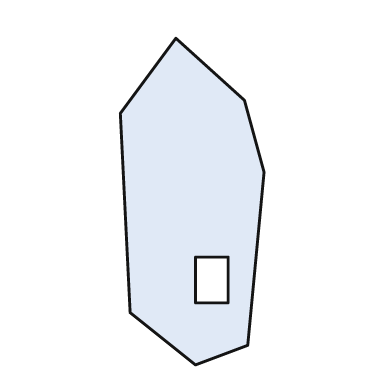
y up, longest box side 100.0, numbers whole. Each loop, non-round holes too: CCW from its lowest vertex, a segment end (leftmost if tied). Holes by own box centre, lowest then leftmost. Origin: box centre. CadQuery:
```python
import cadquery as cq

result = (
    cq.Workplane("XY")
    .moveTo(1.0, -50.0)
    .lineTo(17.0, -44.0)
    .lineTo(22.0, 9.0)
    .lineTo(16.0, 31.0)
    .lineTo(-5.0, 50.0)
    .lineTo(-22.0, 27.0)
    .lineTo(-19.0, -34.0)
    .close()
    .moveTo(1.0, -31.0)
    .lineTo(11.0, -31.0)
    .lineTo(11.0, -17.0)
    .lineTo(1.0, -17.0)
    .close()
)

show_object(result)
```